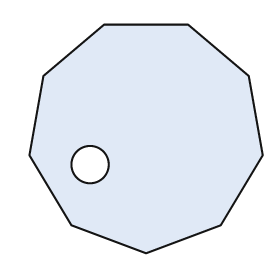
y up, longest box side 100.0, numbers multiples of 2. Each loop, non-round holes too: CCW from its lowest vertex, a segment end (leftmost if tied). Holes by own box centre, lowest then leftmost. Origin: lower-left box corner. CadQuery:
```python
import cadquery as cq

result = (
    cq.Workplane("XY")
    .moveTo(50.0, 0.0)
    .lineTo(82.0, 12.0)
    .lineTo(100.0, 42.0)
    .lineTo(94.0, 76.0)
    .lineTo(68.0, 98.0)
    .lineTo(32.0, 98.0)
    .lineTo(6.0, 76.0)
    .lineTo(0.0, 42.0)
    .lineTo(18.0, 12.0)
    .close()
    .moveTo(26.0, 38.0)
    .circle(8.0)
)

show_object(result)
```